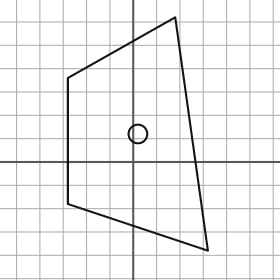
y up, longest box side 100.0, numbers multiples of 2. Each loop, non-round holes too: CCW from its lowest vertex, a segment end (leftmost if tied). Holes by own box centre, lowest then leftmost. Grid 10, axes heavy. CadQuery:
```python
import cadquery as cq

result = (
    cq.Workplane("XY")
    .moveTo(32.0, -38.0)
    .lineTo(18.0, 62.0)
    .lineTo(-28.0, 36.0)
    .lineTo(-28.0, -18.0)
    .close()
    .moveTo(2.0, 12.0)
    .circle(4.0)
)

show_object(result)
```